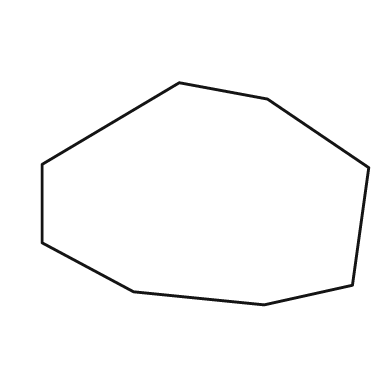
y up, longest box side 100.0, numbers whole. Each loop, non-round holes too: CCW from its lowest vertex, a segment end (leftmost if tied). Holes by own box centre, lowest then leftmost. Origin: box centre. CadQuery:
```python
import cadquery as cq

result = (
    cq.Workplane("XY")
    .moveTo(18.0, -34.0)
    .lineTo(45.0, -28.0)
    .lineTo(50.0, 8.0)
    .lineTo(19.0, 29.0)
    .lineTo(-8.0, 34.0)
    .lineTo(-50.0, 9.0)
    .lineTo(-50.0, -15.0)
    .lineTo(-22.0, -30.0)
    .close()
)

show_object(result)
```